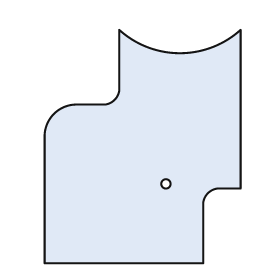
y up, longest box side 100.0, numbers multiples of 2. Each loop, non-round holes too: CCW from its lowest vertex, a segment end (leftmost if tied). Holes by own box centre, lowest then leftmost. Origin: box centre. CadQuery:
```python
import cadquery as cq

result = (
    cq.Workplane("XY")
    .moveTo(-42.0, -50.0)
    .lineTo(26.0, -50.0)
    .lineTo(26.0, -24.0)
    .threePointArc((28.0, -20.0), (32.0, -18.0))
    .lineTo(42.0, -18.0)
    .lineTo(42.0, 50.0)
    .threePointArc((16.0, 40.0), (-10.0, 50.0))
    .lineTo(-10.0, 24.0)
    .threePointArc((-12.0, 20.0), (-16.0, 18.0))
    .lineTo(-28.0, 18.0)
    .threePointArc((-38.0, 14.0), (-42.0, 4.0))
    .close()
    .moveTo(10.0, -16.0)
    .circle(2.0)
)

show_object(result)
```